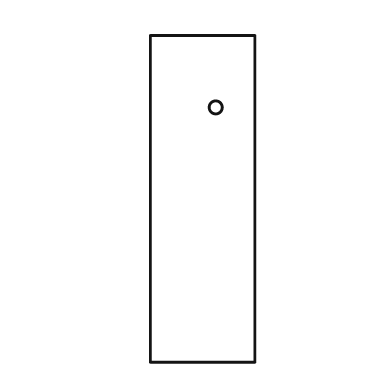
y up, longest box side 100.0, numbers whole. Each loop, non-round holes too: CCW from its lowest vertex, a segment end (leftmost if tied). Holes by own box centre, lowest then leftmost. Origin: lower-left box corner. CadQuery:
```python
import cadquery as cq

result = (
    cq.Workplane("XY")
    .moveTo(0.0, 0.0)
    .lineTo(32.0, 0.0)
    .lineTo(32.0, 100.0)
    .lineTo(0.0, 100.0)
    .close()
    .moveTo(20.0, 78.0)
    .circle(2.0)
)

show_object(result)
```